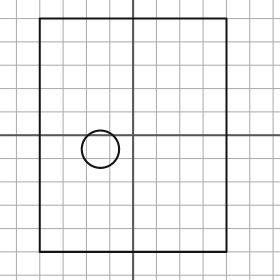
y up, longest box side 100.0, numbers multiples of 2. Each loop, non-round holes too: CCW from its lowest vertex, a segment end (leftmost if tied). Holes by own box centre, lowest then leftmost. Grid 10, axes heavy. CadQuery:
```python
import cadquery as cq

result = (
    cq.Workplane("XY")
    .moveTo(-40.0, -50.0)
    .lineTo(40.0, -50.0)
    .lineTo(40.0, 50.0)
    .lineTo(-40.0, 50.0)
    .close()
    .moveTo(-14.0, -6.0)
    .circle(8.0)
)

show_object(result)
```